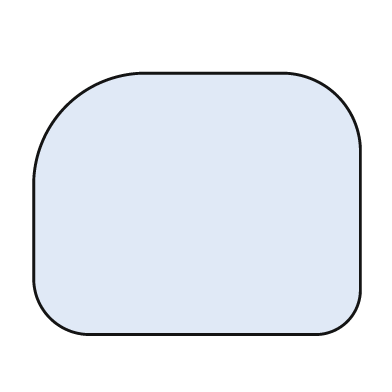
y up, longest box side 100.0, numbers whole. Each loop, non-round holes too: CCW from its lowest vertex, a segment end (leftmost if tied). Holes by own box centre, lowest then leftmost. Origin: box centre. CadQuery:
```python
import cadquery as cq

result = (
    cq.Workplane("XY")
    .moveTo(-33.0, -40.0)
    .lineTo(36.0, -40.0)
    .threePointArc((46.0, -36.0), (50.0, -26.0))
    .lineTo(50.0, 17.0)
    .threePointArc((43.0, 33.0), (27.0, 40.0))
    .lineTo(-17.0, 40.0)
    .threePointArc((-40.0, 30.0), (-50.0, 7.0))
    .lineTo(-50.0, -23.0)
    .threePointArc((-45.0, -35.0), (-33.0, -40.0))
    .close()
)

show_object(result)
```